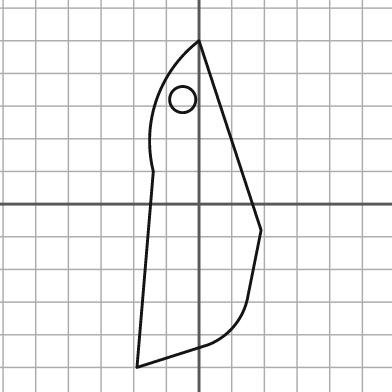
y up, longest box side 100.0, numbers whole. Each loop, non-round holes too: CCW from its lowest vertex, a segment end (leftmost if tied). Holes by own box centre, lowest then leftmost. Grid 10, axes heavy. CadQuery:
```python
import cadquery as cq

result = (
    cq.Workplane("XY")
    .moveTo(-19.0, -50.0)
    .lineTo(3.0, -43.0)
    .threePointArc((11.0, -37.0), (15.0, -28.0))
    .lineTo(19.0, -8.0)
    .lineTo(0.0, 50.0)
    .threePointArc((-13.0, 32.0), (-14.0, 10.0))
    .close()
    .moveTo(-5.0, 32.0)
    .circle(4.0)
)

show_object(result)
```